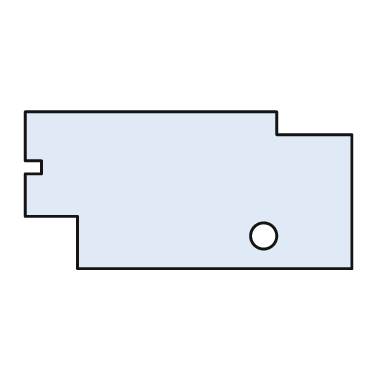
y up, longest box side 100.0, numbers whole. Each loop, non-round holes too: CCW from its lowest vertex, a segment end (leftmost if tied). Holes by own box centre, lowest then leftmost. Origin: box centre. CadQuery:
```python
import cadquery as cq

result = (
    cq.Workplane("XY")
    .moveTo(-34.0, -24.0)
    .lineTo(50.0, -24.0)
    .lineTo(50.0, 17.0)
    .lineTo(27.0, 17.0)
    .lineTo(27.0, 24.0)
    .lineTo(-50.0, 24.0)
    .lineTo(-50.0, 9.0)
    .lineTo(-45.0, 9.0)
    .lineTo(-45.0, 5.0)
    .lineTo(-50.0, 5.0)
    .lineTo(-50.0, -8.0)
    .lineTo(-34.0, -8.0)
    .close()
    .moveTo(23.0, -14.0)
    .circle(4.0)
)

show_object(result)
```